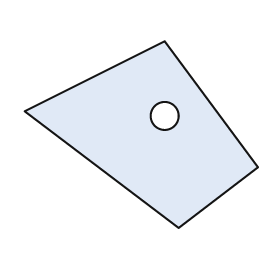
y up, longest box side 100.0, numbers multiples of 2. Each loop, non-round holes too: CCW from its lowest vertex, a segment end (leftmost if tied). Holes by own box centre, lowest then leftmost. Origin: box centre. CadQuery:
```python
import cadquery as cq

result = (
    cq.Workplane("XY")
    .moveTo(16.0, -40.0)
    .lineTo(50.0, -14.0)
    .lineTo(10.0, 40.0)
    .lineTo(-50.0, 10.0)
    .close()
    .moveTo(10.0, 8.0)
    .circle(6.0)
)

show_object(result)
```